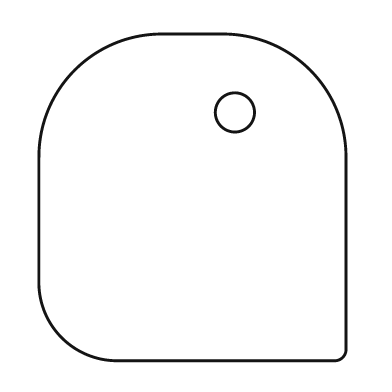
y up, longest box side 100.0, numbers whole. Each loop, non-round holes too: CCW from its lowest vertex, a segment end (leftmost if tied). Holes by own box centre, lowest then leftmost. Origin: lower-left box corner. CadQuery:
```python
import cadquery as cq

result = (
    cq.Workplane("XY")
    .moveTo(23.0, 0.0)
    .lineTo(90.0, 0.0)
    .threePointArc((93.0, 1.0), (94.0, 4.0))
    .lineTo(94.0, 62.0)
    .threePointArc((83.0, 89.0), (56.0, 100.0))
    .lineTo(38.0, 100.0)
    .threePointArc((11.0, 89.0), (0.0, 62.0))
    .lineTo(0.0, 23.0)
    .threePointArc((7.0, 7.0), (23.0, 0.0))
    .close()
    .moveTo(60.0, 76.0)
    .circle(6.0)
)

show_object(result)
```